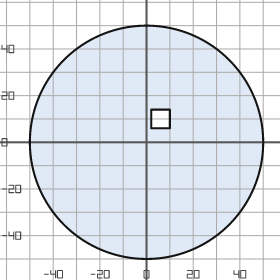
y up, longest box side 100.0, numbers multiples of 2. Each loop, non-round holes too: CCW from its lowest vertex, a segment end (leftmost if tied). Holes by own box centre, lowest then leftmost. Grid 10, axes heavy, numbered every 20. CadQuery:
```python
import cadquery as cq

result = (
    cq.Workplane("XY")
    .moveTo(0.0, 0.0)
    .circle(50.0)
    .moveTo(2.0, 6.0)
    .lineTo(10.0, 6.0)
    .lineTo(10.0, 14.0)
    .lineTo(2.0, 14.0)
    .close()
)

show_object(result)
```